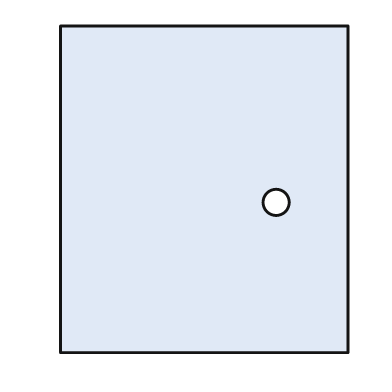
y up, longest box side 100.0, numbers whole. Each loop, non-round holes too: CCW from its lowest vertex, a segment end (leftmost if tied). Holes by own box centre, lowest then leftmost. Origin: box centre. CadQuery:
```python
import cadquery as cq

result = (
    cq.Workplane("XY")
    .moveTo(-44.0, -50.0)
    .lineTo(44.0, -50.0)
    .lineTo(44.0, 50.0)
    .lineTo(-44.0, 50.0)
    .close()
    .moveTo(22.0, -4.0)
    .circle(4.0)
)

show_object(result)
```